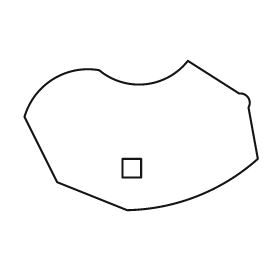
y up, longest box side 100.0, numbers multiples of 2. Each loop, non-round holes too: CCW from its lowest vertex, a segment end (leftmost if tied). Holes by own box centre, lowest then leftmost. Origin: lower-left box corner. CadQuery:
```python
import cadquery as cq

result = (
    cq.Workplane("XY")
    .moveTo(44.0, 0.0)
    .threePointArc((74.0, 6.0), (100.0, 22.0))
    .lineTo(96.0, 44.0)
    .threePointArc((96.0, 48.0), (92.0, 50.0))
    .lineTo(70.0, 64.0)
    .threePointArc((52.0, 54.0), (32.0, 60.0))
    .threePointArc((12.0, 56.0), (0.0, 40.0))
    .lineTo(14.0, 12.0)
    .close()
    .moveTo(42.0, 14.0)
    .lineTo(50.0, 14.0)
    .lineTo(50.0, 22.0)
    .lineTo(42.0, 22.0)
    .close()
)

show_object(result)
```